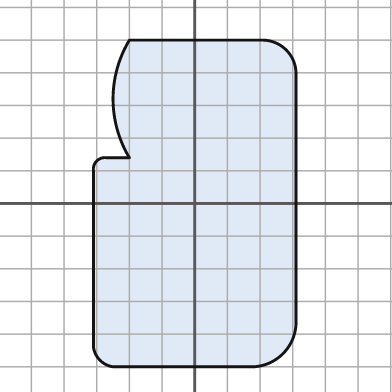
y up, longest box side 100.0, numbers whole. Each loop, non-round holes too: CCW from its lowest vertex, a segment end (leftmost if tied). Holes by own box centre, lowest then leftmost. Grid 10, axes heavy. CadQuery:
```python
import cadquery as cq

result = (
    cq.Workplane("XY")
    .moveTo(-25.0, -50.0)
    .lineTo(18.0, -50.0)
    .threePointArc((27.0, -46.0), (31.0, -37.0))
    .lineTo(31.0, 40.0)
    .threePointArc((28.0, 47.0), (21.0, 50.0))
    .lineTo(-20.0, 50.0)
    .threePointArc((-25.0, 32.0), (-20.0, 14.0))
    .lineTo(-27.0, 14.0)
    .threePointArc((-30.0, 13.0), (-31.0, 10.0))
    .lineTo(-31.0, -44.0)
    .threePointArc((-29.0, -48.0), (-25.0, -50.0))
    .close()
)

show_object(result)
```